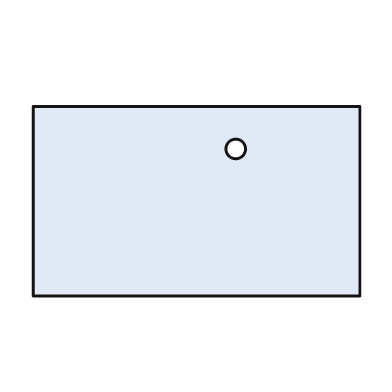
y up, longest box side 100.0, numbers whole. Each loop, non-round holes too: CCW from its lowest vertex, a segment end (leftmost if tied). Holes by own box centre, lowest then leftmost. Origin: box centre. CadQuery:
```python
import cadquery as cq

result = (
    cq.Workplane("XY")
    .moveTo(-50.0, -29.0)
    .lineTo(50.0, -29.0)
    .lineTo(50.0, 29.0)
    .lineTo(-50.0, 29.0)
    .close()
    .moveTo(12.0, 16.0)
    .circle(3.0)
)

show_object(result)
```